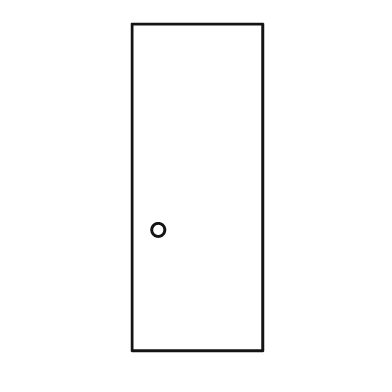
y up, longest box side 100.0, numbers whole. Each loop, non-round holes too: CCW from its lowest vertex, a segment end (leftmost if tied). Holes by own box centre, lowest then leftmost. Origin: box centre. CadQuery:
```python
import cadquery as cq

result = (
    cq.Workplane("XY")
    .moveTo(-20.0, -50.0)
    .lineTo(20.0, -50.0)
    .lineTo(20.0, 50.0)
    .lineTo(-20.0, 50.0)
    .close()
    .moveTo(-12.0, -13.0)
    .circle(2.0)
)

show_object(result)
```